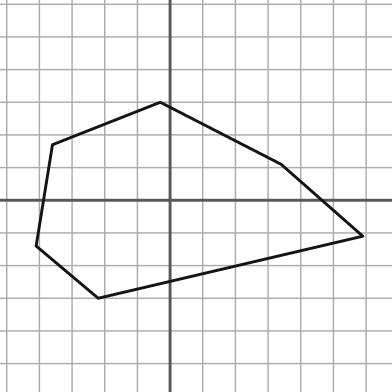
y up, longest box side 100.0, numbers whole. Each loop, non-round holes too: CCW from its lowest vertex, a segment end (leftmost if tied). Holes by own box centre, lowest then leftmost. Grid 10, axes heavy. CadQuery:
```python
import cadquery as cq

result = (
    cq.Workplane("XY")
    .moveTo(-22.0, -30.0)
    .lineTo(59.0, -11.0)
    .lineTo(34.0, 11.0)
    .lineTo(-3.0, 30.0)
    .lineTo(-36.0, 17.0)
    .lineTo(-41.0, -14.0)
    .close()
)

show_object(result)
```